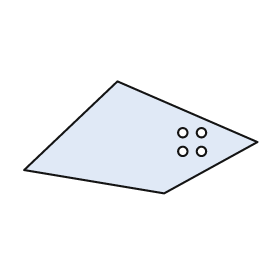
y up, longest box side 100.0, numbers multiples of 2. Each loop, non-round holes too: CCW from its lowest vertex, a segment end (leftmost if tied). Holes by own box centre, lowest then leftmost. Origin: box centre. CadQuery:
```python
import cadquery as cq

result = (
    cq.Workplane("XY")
    .moveTo(10.0, -24.0)
    .lineTo(50.0, -2.0)
    .lineTo(-10.0, 24.0)
    .lineTo(-50.0, -14.0)
    .close()
    .moveTo(18.0, -6.0)
    .circle(2.0)
    .moveTo(26.0, -6.0)
    .circle(2.0)
    .moveTo(18.0, 2.0)
    .circle(2.0)
    .moveTo(26.0, 2.0)
    .circle(2.0)
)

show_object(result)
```